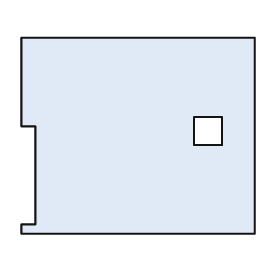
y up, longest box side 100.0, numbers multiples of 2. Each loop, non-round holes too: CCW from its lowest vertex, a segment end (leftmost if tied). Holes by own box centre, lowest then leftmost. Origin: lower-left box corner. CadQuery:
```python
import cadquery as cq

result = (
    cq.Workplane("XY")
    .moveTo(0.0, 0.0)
    .lineTo(100.0, 0.0)
    .lineTo(100.0, 84.0)
    .lineTo(0.0, 84.0)
    .lineTo(0.0, 46.0)
    .lineTo(6.0, 46.0)
    .lineTo(6.0, 4.0)
    .lineTo(0.0, 4.0)
    .close()
    .moveTo(74.0, 38.0)
    .lineTo(86.0, 38.0)
    .lineTo(86.0, 50.0)
    .lineTo(74.0, 50.0)
    .close()
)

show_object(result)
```